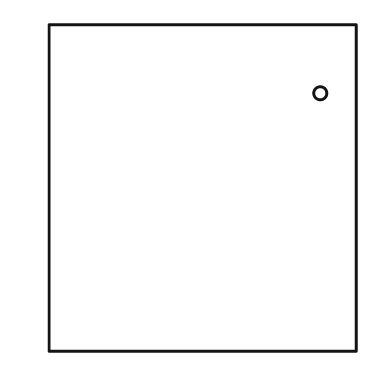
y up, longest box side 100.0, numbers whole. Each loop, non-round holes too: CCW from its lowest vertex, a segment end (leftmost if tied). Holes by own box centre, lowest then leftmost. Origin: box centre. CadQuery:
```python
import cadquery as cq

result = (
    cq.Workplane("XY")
    .moveTo(-47.0, -50.0)
    .lineTo(47.0, -50.0)
    .lineTo(47.0, 50.0)
    .lineTo(-47.0, 50.0)
    .close()
    .moveTo(36.0, 29.0)
    .circle(2.0)
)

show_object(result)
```